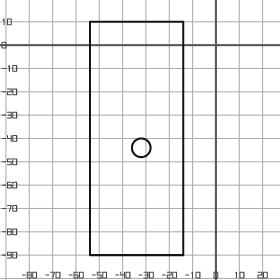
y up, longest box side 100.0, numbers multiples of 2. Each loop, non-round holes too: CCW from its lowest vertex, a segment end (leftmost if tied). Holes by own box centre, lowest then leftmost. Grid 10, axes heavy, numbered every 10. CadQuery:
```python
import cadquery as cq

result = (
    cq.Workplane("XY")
    .moveTo(-54.0, -90.0)
    .lineTo(-14.0, -90.0)
    .lineTo(-14.0, 10.0)
    .lineTo(-54.0, 10.0)
    .close()
    .moveTo(-32.0, -44.0)
    .circle(4.0)
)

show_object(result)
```